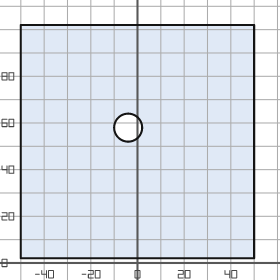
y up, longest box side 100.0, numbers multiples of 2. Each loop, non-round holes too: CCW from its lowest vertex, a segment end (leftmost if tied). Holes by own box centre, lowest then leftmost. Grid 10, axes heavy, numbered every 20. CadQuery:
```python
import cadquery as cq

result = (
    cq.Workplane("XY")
    .moveTo(-50.0, 2.0)
    .lineTo(50.0, 2.0)
    .lineTo(50.0, 102.0)
    .lineTo(-50.0, 102.0)
    .close()
    .moveTo(-4.0, 58.0)
    .circle(6.0)
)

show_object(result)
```